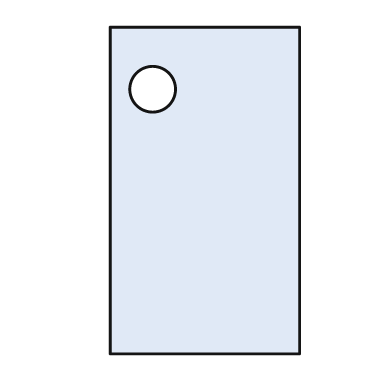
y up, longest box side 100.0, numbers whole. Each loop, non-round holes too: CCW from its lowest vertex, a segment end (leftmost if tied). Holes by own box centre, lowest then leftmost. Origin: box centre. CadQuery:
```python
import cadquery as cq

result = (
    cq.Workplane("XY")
    .moveTo(-29.0, -50.0)
    .lineTo(29.0, -50.0)
    .lineTo(29.0, 50.0)
    .lineTo(-29.0, 50.0)
    .close()
    .moveTo(-16.0, 31.0)
    .circle(7.0)
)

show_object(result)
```